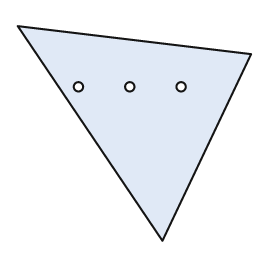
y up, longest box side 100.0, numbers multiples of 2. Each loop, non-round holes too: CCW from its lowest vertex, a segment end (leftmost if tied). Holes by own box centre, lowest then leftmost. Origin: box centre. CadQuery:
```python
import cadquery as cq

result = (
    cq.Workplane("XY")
    .moveTo(12.0, -46.0)
    .lineTo(50.0, 34.0)
    .lineTo(-50.0, 46.0)
    .close()
    .moveTo(-24.0, 20.0)
    .circle(2.0)
    .moveTo(-2.0, 20.0)
    .circle(2.0)
    .moveTo(20.0, 20.0)
    .circle(2.0)
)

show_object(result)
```